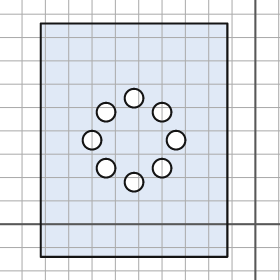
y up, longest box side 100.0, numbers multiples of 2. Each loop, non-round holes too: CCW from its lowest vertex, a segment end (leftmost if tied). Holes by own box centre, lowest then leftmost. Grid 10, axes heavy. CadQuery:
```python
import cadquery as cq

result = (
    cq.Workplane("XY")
    .moveTo(-92.0, -14.0)
    .lineTo(-12.0, -14.0)
    .lineTo(-12.0, 86.0)
    .lineTo(-92.0, 86.0)
    .close()
    .moveTo(-52.0, 18.0)
    .circle(4.0)
    .moveTo(-64.0, 24.0)
    .circle(4.0)
    .moveTo(-40.0, 24.0)
    .circle(4.0)
    .moveTo(-70.0, 36.0)
    .circle(4.0)
    .moveTo(-34.0, 36.0)
    .circle(4.0)
    .moveTo(-64.0, 48.0)
    .circle(4.0)
    .moveTo(-40.0, 48.0)
    .circle(4.0)
    .moveTo(-52.0, 54.0)
    .circle(4.0)
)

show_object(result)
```